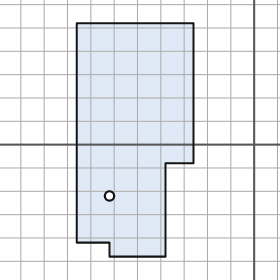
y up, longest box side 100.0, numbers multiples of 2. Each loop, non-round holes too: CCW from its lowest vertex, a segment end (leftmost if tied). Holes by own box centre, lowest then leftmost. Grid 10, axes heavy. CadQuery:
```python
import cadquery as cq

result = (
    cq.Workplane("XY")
    .moveTo(-62.0, -48.0)
    .lineTo(-38.0, -48.0)
    .lineTo(-38.0, -8.0)
    .lineTo(-26.0, -8.0)
    .lineTo(-26.0, 52.0)
    .lineTo(-76.0, 52.0)
    .lineTo(-76.0, -42.0)
    .lineTo(-62.0, -42.0)
    .close()
    .moveTo(-62.0, -22.0)
    .circle(2.0)
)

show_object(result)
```